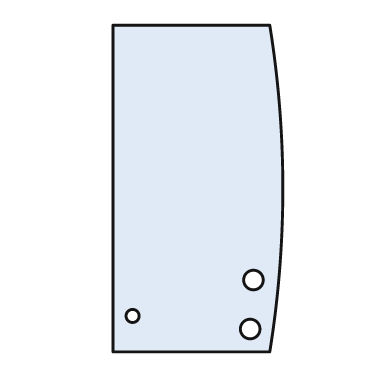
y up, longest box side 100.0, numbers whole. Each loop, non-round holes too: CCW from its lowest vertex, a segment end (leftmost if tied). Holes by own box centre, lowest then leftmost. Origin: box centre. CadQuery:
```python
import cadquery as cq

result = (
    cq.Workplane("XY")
    .moveTo(-26.0, -50.0)
    .lineTo(22.0, -50.0)
    .threePointArc((26.0, 0.0), (22.0, 50.0))
    .lineTo(-26.0, 50.0)
    .close()
    .moveTo(16.0, -43.0)
    .circle(3.0)
    .moveTo(-20.0, -39.0)
    .circle(2.0)
    .moveTo(17.0, -28.0)
    .circle(3.0)
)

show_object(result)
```